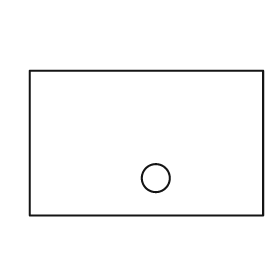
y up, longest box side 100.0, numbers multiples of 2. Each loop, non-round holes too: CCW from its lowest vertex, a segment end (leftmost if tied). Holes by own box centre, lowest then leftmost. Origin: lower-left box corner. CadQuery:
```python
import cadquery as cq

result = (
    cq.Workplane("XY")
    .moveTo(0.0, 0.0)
    .lineTo(100.0, 0.0)
    .lineTo(100.0, 62.0)
    .lineTo(0.0, 62.0)
    .close()
    .moveTo(54.0, 16.0)
    .circle(6.0)
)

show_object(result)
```